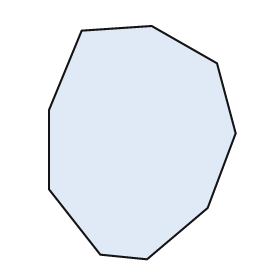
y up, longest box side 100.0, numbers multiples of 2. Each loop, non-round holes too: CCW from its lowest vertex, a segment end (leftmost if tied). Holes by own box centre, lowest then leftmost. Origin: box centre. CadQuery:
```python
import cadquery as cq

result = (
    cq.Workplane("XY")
    .moveTo(2.0, -50.0)
    .lineTo(28.0, -28.0)
    .lineTo(40.0, 4.0)
    .lineTo(32.0, 34.0)
    .lineTo(4.0, 50.0)
    .lineTo(-26.0, 48.0)
    .lineTo(-40.0, 14.0)
    .lineTo(-40.0, -20.0)
    .lineTo(-18.0, -48.0)
    .close()
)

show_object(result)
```